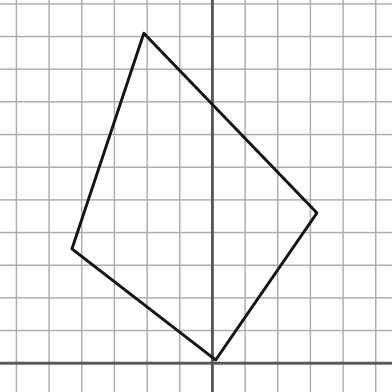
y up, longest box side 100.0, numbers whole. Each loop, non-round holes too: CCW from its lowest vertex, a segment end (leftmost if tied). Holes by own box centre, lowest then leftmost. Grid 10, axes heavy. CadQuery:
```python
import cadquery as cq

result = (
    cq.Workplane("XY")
    .moveTo(1.0, 1.0)
    .lineTo(32.0, 46.0)
    .lineTo(-21.0, 101.0)
    .lineTo(-43.0, 35.0)
    .close()
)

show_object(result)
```